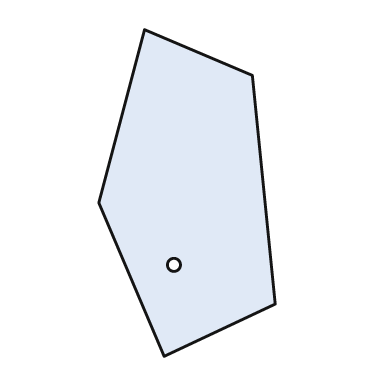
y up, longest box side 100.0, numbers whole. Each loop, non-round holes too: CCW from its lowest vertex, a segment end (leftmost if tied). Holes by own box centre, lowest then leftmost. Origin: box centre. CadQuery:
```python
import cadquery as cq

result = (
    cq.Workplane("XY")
    .moveTo(-7.0, -50.0)
    .lineTo(27.0, -34.0)
    .lineTo(20.0, 36.0)
    .lineTo(-13.0, 50.0)
    .lineTo(-27.0, -3.0)
    .close()
    .moveTo(-4.0, -22.0)
    .circle(2.0)
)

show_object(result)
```